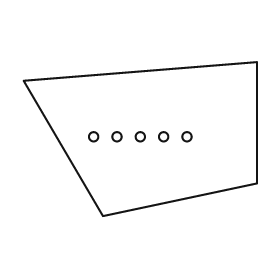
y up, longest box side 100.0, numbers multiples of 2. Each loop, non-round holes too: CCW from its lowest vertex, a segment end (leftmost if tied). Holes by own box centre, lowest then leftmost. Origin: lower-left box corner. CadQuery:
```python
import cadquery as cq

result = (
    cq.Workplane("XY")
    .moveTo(34.0, 0.0)
    .lineTo(100.0, 14.0)
    .lineTo(100.0, 66.0)
    .lineTo(0.0, 58.0)
    .close()
    .moveTo(30.0, 34.0)
    .circle(2.0)
    .moveTo(40.0, 34.0)
    .circle(2.0)
    .moveTo(50.0, 34.0)
    .circle(2.0)
    .moveTo(60.0, 34.0)
    .circle(2.0)
    .moveTo(70.0, 34.0)
    .circle(2.0)
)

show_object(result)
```